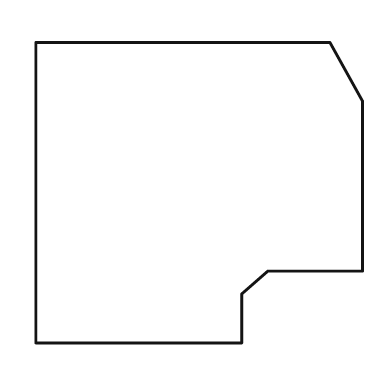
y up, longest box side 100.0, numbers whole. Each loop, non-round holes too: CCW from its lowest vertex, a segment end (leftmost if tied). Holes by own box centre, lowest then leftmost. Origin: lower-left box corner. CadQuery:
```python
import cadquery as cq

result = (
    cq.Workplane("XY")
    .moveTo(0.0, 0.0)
    .lineTo(63.0, 0.0)
    .lineTo(63.0, 15.0)
    .lineTo(71.0, 22.0)
    .lineTo(100.0, 22.0)
    .lineTo(100.0, 74.0)
    .lineTo(90.0, 92.0)
    .lineTo(0.0, 92.0)
    .close()
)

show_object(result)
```